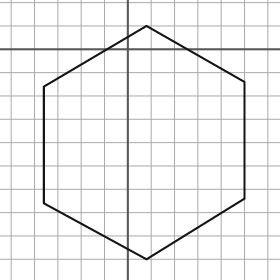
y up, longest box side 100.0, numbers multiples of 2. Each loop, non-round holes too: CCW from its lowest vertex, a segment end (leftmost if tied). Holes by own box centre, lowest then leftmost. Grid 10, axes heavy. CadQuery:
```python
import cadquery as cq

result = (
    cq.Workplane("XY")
    .moveTo(8.0, -90.0)
    .lineTo(50.0, -64.0)
    .lineTo(50.0, -14.0)
    .lineTo(8.0, 10.0)
    .lineTo(-36.0, -16.0)
    .lineTo(-36.0, -66.0)
    .close()
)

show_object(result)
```